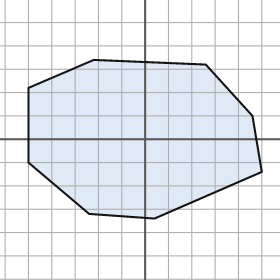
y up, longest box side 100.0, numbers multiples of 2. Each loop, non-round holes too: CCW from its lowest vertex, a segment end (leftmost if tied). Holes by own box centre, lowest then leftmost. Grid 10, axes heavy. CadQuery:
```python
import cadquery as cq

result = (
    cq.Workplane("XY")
    .moveTo(4.0, -34.0)
    .lineTo(50.0, -14.0)
    .lineTo(46.0, 10.0)
    .lineTo(26.0, 32.0)
    .lineTo(-22.0, 34.0)
    .lineTo(-50.0, 22.0)
    .lineTo(-50.0, -10.0)
    .lineTo(-24.0, -32.0)
    .close()
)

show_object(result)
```